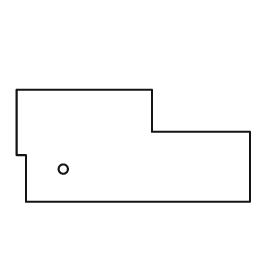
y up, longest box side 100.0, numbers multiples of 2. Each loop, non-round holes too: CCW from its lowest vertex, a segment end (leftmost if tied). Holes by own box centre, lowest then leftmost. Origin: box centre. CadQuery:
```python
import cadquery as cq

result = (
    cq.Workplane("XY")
    .moveTo(-46.0, -24.0)
    .lineTo(50.0, -24.0)
    .lineTo(50.0, 6.0)
    .lineTo(8.0, 6.0)
    .lineTo(8.0, 24.0)
    .lineTo(-50.0, 24.0)
    .lineTo(-50.0, -4.0)
    .lineTo(-46.0, -4.0)
    .close()
    .moveTo(-30.0, -10.0)
    .circle(2.0)
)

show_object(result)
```